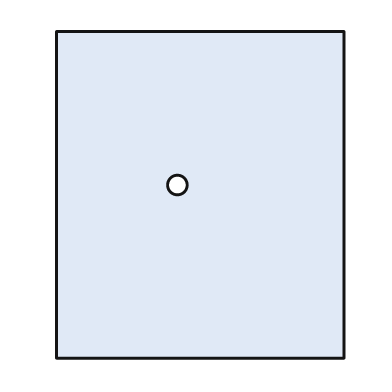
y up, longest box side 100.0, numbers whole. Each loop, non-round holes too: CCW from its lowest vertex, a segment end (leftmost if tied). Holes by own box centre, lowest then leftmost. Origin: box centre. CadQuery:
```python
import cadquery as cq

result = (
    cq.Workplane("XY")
    .moveTo(-44.0, -50.0)
    .lineTo(44.0, -50.0)
    .lineTo(44.0, 50.0)
    .lineTo(-44.0, 50.0)
    .close()
    .moveTo(-7.0, 3.0)
    .circle(3.0)
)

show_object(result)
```